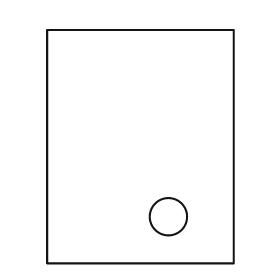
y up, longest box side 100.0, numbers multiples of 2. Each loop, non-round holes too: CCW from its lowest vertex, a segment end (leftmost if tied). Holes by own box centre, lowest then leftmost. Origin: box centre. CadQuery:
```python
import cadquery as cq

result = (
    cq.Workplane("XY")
    .moveTo(-40.0, -50.0)
    .lineTo(40.0, -50.0)
    .lineTo(40.0, 50.0)
    .lineTo(-40.0, 50.0)
    .close()
    .moveTo(12.0, -30.0)
    .circle(8.0)
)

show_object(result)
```